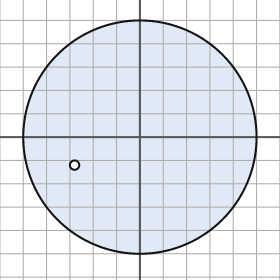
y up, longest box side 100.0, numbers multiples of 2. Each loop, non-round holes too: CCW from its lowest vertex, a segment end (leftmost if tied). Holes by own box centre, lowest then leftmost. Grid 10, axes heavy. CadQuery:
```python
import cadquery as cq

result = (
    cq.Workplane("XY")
    .moveTo(0.0, 0.0)
    .circle(50.0)
    .moveTo(-28.0, -12.0)
    .circle(2.0)
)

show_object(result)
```